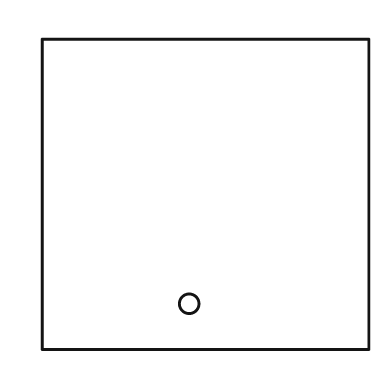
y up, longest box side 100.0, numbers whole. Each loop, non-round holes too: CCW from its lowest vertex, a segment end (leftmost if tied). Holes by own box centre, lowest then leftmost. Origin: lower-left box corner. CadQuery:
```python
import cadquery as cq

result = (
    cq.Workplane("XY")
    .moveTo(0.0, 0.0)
    .lineTo(100.0, 0.0)
    .lineTo(100.0, 95.0)
    .lineTo(0.0, 95.0)
    .close()
    .moveTo(45.0, 14.0)
    .circle(3.0)
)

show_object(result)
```